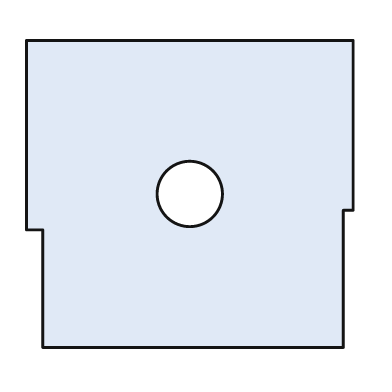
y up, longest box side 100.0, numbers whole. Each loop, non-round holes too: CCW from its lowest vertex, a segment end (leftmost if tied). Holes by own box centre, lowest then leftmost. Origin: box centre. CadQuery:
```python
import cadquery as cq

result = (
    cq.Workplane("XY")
    .moveTo(-45.0, -47.0)
    .lineTo(47.0, -47.0)
    .lineTo(47.0, -5.0)
    .lineTo(50.0, -5.0)
    .lineTo(50.0, 47.0)
    .lineTo(-50.0, 47.0)
    .lineTo(-50.0, -11.0)
    .lineTo(-45.0, -11.0)
    .close()
    .moveTo(0.0, 0.0)
    .circle(10.0)
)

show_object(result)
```